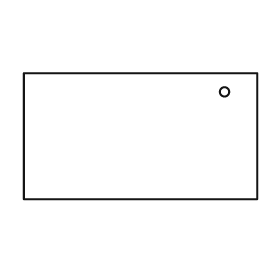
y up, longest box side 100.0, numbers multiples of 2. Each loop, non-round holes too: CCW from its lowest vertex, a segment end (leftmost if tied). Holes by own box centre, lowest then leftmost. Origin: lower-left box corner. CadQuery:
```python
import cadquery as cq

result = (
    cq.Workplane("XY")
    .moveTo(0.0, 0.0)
    .lineTo(100.0, 0.0)
    .lineTo(100.0, 54.0)
    .lineTo(0.0, 54.0)
    .close()
    .moveTo(86.0, 46.0)
    .circle(2.0)
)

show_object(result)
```